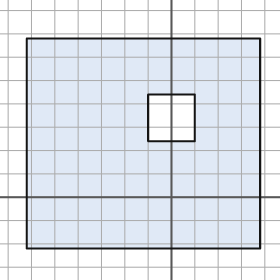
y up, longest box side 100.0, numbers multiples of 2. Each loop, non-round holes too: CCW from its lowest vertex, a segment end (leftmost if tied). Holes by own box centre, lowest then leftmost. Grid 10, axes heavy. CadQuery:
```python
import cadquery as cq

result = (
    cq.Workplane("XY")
    .moveTo(-62.0, -22.0)
    .lineTo(38.0, -22.0)
    .lineTo(38.0, 68.0)
    .lineTo(-62.0, 68.0)
    .close()
    .moveTo(-10.0, 24.0)
    .lineTo(10.0, 24.0)
    .lineTo(10.0, 44.0)
    .lineTo(-10.0, 44.0)
    .close()
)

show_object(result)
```